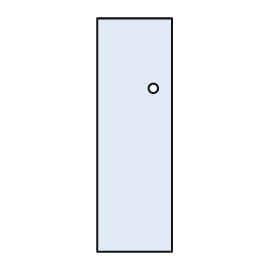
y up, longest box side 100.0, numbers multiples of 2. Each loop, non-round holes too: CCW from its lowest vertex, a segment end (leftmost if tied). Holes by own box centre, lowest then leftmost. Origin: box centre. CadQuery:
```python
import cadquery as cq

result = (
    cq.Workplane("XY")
    .moveTo(-16.0, -50.0)
    .lineTo(16.0, -50.0)
    .lineTo(16.0, 50.0)
    .lineTo(-16.0, 50.0)
    .close()
    .moveTo(8.0, 20.0)
    .circle(2.0)
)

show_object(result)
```